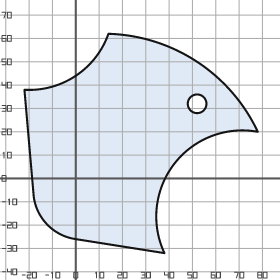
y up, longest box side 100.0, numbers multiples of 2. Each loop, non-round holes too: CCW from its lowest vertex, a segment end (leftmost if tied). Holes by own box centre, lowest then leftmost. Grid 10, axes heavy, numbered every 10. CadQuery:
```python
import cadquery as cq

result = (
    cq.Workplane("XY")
    .moveTo(38.0, -32.0)
    .threePointArc((42.0, 6.0), (78.0, 20.0))
    .threePointArc((52.0, 50.0), (14.0, 62.0))
    .threePointArc((0.0, 44.0), (-22.0, 38.0))
    .lineTo(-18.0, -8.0)
    .threePointArc((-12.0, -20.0), (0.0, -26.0))
    .close()
    .moveTo(52.0, 32.0)
    .circle(4.0)
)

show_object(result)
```